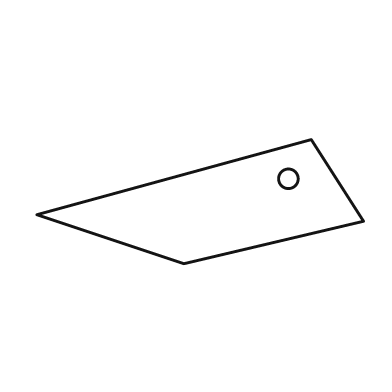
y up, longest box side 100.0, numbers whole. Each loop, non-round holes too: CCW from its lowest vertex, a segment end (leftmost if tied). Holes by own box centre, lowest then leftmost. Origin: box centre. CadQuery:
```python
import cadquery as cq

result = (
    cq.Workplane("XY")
    .moveTo(-5.0, -19.0)
    .lineTo(50.0, -6.0)
    .lineTo(34.0, 19.0)
    .lineTo(-50.0, -4.0)
    .close()
    .moveTo(27.0, 7.0)
    .circle(3.0)
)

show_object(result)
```